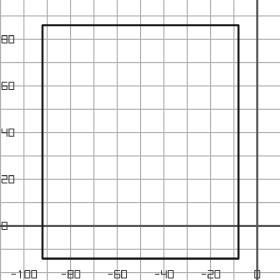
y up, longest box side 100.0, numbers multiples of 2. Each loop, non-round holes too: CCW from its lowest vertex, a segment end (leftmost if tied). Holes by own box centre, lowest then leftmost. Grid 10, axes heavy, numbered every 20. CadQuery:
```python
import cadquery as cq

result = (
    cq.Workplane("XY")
    .moveTo(-92.0, -14.0)
    .lineTo(-8.0, -14.0)
    .lineTo(-8.0, 86.0)
    .lineTo(-92.0, 86.0)
    .close()
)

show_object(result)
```